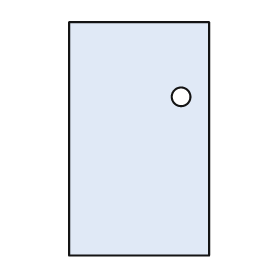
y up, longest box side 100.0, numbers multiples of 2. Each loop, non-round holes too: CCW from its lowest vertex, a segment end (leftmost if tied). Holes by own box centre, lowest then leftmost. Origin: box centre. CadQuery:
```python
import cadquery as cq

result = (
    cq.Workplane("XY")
    .moveTo(-30.0, -50.0)
    .lineTo(30.0, -50.0)
    .lineTo(30.0, 50.0)
    .lineTo(-30.0, 50.0)
    .close()
    .moveTo(18.0, 18.0)
    .circle(4.0)
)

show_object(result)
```